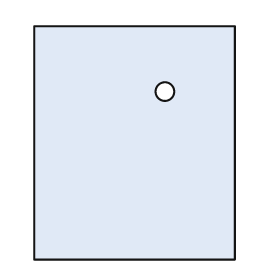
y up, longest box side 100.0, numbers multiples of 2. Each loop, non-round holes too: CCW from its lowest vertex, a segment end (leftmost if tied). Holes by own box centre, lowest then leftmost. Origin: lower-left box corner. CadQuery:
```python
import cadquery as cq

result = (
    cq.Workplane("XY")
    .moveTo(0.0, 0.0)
    .lineTo(86.0, 0.0)
    .lineTo(86.0, 100.0)
    .lineTo(0.0, 100.0)
    .close()
    .moveTo(56.0, 72.0)
    .circle(4.0)
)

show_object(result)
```